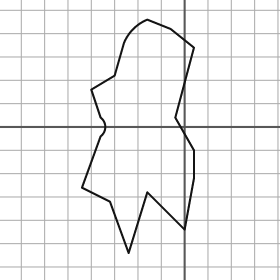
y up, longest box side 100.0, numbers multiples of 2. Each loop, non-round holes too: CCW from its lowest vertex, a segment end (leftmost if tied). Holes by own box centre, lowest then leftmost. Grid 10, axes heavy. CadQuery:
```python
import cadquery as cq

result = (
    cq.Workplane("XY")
    .moveTo(-24.0, -54.0)
    .lineTo(-16.0, -28.0)
    .lineTo(0.0, -44.0)
    .lineTo(4.0, -22.0)
    .lineTo(4.0, -10.0)
    .lineTo(-4.0, 4.0)
    .lineTo(4.0, 34.0)
    .lineTo(-6.0, 42.0)
    .lineTo(-16.0, 46.0)
    .threePointArc((-22.0, 42.0), (-26.0, 36.0))
    .lineTo(-30.0, 22.0)
    .lineTo(-40.0, 16.0)
    .lineTo(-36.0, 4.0)
    .threePointArc((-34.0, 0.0), (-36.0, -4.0))
    .lineTo(-44.0, -26.0)
    .lineTo(-32.0, -32.0)
    .close()
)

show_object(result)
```